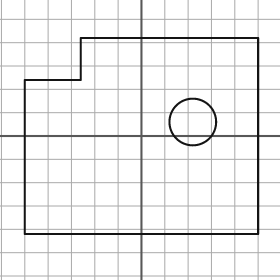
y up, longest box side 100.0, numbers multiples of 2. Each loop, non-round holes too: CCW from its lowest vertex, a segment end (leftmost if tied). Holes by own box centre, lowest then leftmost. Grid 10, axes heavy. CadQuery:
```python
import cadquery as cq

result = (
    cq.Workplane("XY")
    .moveTo(-50.0, -42.0)
    .lineTo(50.0, -42.0)
    .lineTo(50.0, 42.0)
    .lineTo(-26.0, 42.0)
    .lineTo(-26.0, 24.0)
    .lineTo(-50.0, 24.0)
    .close()
    .moveTo(22.0, 6.0)
    .circle(10.0)
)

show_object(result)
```